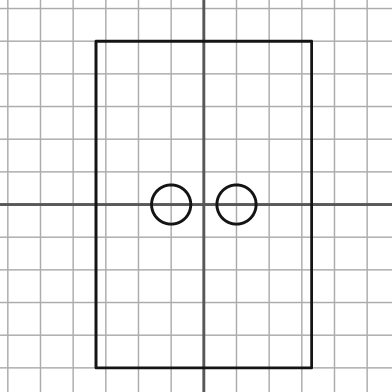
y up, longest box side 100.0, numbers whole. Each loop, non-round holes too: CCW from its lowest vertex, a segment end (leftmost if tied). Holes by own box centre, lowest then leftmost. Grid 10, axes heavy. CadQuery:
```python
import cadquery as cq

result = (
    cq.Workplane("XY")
    .moveTo(-33.0, -50.0)
    .lineTo(33.0, -50.0)
    .lineTo(33.0, 50.0)
    .lineTo(-33.0, 50.0)
    .close()
    .moveTo(-10.0, 0.0)
    .circle(6.0)
    .moveTo(10.0, 0.0)
    .circle(6.0)
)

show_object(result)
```